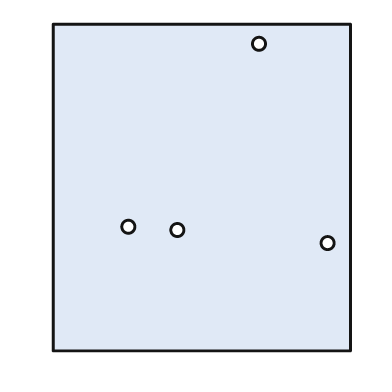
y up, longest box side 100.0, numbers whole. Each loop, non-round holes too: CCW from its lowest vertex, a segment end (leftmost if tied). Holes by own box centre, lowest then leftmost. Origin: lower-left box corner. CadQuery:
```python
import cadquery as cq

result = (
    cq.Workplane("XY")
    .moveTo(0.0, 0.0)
    .lineTo(91.0, 0.0)
    .lineTo(91.0, 100.0)
    .lineTo(0.0, 100.0)
    .close()
    .moveTo(84.0, 33.0)
    .circle(2.0)
    .moveTo(38.0, 37.0)
    .circle(2.0)
    .moveTo(23.0, 38.0)
    .circle(2.0)
    .moveTo(63.0, 94.0)
    .circle(2.0)
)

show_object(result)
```